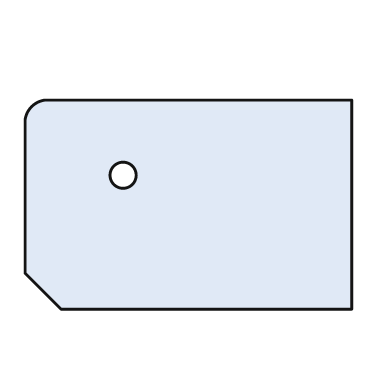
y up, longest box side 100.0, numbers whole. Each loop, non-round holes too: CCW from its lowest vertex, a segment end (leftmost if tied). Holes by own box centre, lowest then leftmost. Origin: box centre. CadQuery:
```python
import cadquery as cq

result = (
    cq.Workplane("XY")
    .moveTo(-39.0, -32.0)
    .lineTo(50.0, -32.0)
    .lineTo(50.0, 32.0)
    .lineTo(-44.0, 32.0)
    .threePointArc((-48.0, 30.0), (-50.0, 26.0))
    .lineTo(-50.0, -21.0)
    .close()
    .moveTo(-20.0, 9.0)
    .circle(4.0)
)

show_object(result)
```